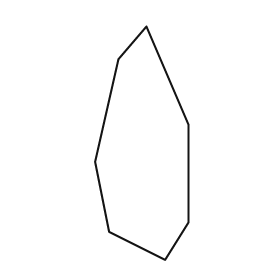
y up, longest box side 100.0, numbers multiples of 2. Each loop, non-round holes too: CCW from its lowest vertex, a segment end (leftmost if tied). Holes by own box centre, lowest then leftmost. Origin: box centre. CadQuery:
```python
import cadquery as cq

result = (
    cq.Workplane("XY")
    .moveTo(10.0, -50.0)
    .lineTo(20.0, -34.0)
    .lineTo(20.0, 8.0)
    .lineTo(2.0, 50.0)
    .lineTo(-10.0, 36.0)
    .lineTo(-20.0, -8.0)
    .lineTo(-14.0, -38.0)
    .close()
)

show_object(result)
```